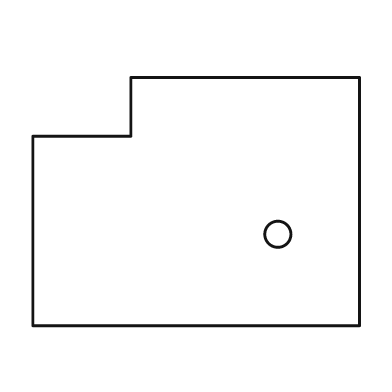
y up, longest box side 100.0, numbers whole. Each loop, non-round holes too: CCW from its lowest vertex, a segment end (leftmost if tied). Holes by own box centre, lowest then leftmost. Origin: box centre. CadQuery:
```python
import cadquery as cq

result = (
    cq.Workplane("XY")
    .moveTo(-50.0, -38.0)
    .lineTo(50.0, -38.0)
    .lineTo(50.0, 38.0)
    .lineTo(-20.0, 38.0)
    .lineTo(-20.0, 20.0)
    .lineTo(-50.0, 20.0)
    .close()
    .moveTo(25.0, -10.0)
    .circle(4.0)
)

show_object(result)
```